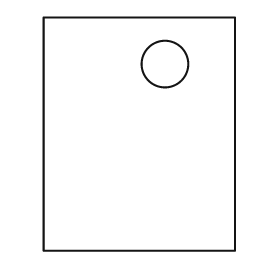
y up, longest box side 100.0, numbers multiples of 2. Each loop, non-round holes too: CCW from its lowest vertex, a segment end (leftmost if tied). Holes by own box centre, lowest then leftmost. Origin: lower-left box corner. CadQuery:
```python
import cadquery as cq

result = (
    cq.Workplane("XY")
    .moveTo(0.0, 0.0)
    .lineTo(82.0, 0.0)
    .lineTo(82.0, 100.0)
    .lineTo(0.0, 100.0)
    .close()
    .moveTo(52.0, 80.0)
    .circle(10.0)
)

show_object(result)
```